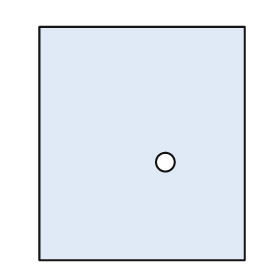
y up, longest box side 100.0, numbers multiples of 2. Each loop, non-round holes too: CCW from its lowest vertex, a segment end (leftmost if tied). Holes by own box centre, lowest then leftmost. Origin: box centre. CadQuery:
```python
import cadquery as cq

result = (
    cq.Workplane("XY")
    .moveTo(-44.0, -50.0)
    .lineTo(44.0, -50.0)
    .lineTo(44.0, 50.0)
    .lineTo(-44.0, 50.0)
    .close()
    .moveTo(10.0, -8.0)
    .circle(4.0)
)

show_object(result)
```